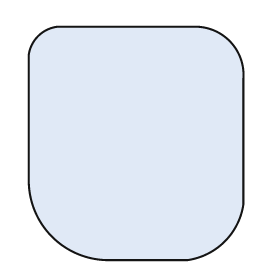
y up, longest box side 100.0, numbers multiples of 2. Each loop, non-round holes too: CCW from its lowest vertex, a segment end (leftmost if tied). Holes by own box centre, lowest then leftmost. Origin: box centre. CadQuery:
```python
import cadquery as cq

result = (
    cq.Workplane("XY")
    .moveTo(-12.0, -50.0)
    .lineTo(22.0, -50.0)
    .threePointArc((38.0, -42.0), (46.0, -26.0))
    .lineTo(46.0, 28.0)
    .threePointArc((40.0, 44.0), (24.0, 50.0))
    .lineTo(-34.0, 50.0)
    .threePointArc((-42.0, 46.0), (-46.0, 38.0))
    .lineTo(-46.0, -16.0)
    .threePointArc((-36.0, -40.0), (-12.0, -50.0))
    .close()
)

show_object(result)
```